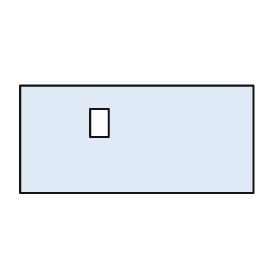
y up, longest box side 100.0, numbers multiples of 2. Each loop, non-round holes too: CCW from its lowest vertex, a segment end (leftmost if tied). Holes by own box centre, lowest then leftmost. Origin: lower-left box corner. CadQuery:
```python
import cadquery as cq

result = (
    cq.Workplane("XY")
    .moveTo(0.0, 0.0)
    .lineTo(100.0, 0.0)
    .lineTo(100.0, 46.0)
    .lineTo(0.0, 46.0)
    .close()
    .moveTo(30.0, 24.0)
    .lineTo(38.0, 24.0)
    .lineTo(38.0, 36.0)
    .lineTo(30.0, 36.0)
    .close()
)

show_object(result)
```